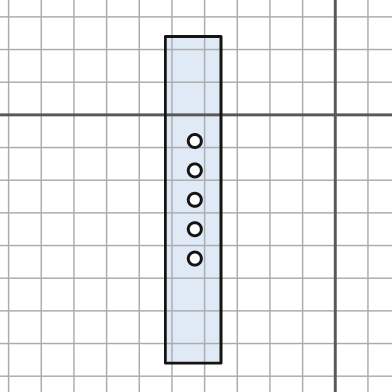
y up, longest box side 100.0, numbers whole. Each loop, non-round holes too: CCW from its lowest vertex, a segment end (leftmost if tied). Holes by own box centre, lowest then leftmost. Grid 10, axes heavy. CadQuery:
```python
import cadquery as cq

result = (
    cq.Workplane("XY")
    .moveTo(-52.0, -76.0)
    .lineTo(-35.0, -76.0)
    .lineTo(-35.0, 24.0)
    .lineTo(-52.0, 24.0)
    .close()
    .moveTo(-43.0, -44.0)
    .circle(2.0)
    .moveTo(-43.0, -35.0)
    .circle(2.0)
    .moveTo(-43.0, -26.0)
    .circle(2.0)
    .moveTo(-43.0, -17.0)
    .circle(2.0)
    .moveTo(-43.0, -8.0)
    .circle(2.0)
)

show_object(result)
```